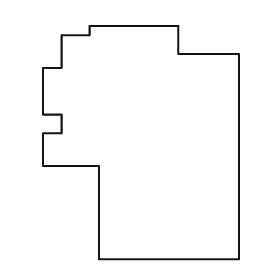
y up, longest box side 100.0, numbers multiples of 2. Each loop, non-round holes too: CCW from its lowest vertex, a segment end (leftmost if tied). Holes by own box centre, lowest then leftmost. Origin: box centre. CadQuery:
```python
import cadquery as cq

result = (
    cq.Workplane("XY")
    .moveTo(-18.0, -50.0)
    .lineTo(42.0, -50.0)
    .lineTo(42.0, 38.0)
    .lineTo(16.0, 38.0)
    .lineTo(16.0, 50.0)
    .lineTo(-22.0, 50.0)
    .lineTo(-22.0, 46.0)
    .lineTo(-34.0, 46.0)
    .lineTo(-34.0, 32.0)
    .lineTo(-42.0, 32.0)
    .lineTo(-42.0, 12.0)
    .lineTo(-34.0, 12.0)
    .lineTo(-34.0, 4.0)
    .lineTo(-42.0, 4.0)
    .lineTo(-42.0, -10.0)
    .lineTo(-18.0, -10.0)
    .close()
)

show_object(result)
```